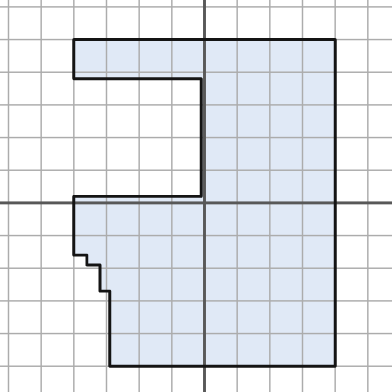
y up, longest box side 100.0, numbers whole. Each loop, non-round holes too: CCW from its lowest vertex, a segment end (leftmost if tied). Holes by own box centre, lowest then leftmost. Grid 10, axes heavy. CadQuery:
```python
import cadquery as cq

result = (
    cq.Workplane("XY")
    .moveTo(-29.0, -50.0)
    .lineTo(40.0, -50.0)
    .lineTo(40.0, 50.0)
    .lineTo(-40.0, 50.0)
    .lineTo(-40.0, 38.0)
    .lineTo(-1.0, 38.0)
    .lineTo(-1.0, 2.0)
    .lineTo(-40.0, 2.0)
    .lineTo(-40.0, -16.0)
    .lineTo(-36.0, -16.0)
    .lineTo(-36.0, -19.0)
    .lineTo(-32.0, -19.0)
    .lineTo(-32.0, -27.0)
    .lineTo(-29.0, -27.0)
    .close()
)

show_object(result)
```